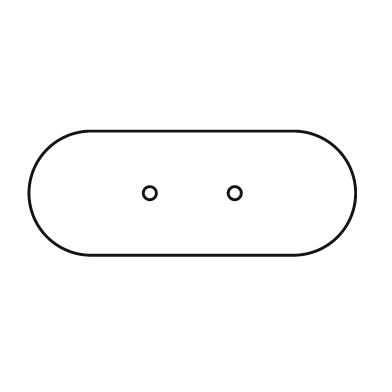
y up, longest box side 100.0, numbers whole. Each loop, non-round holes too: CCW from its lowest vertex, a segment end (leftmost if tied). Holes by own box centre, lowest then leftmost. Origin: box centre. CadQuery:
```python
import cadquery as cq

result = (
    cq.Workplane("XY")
    .moveTo(-31.0, -19.0)
    .lineTo(31.0, -19.0)
    .threePointArc((50.0, 0.0), (31.0, 19.0))
    .lineTo(-31.0, 19.0)
    .threePointArc((-50.0, 0.0), (-31.0, -19.0))
    .close()
    .moveTo(-13.0, 0.0)
    .circle(2.0)
    .moveTo(13.0, 0.0)
    .circle(2.0)
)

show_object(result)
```